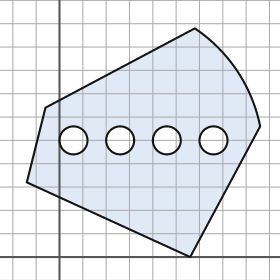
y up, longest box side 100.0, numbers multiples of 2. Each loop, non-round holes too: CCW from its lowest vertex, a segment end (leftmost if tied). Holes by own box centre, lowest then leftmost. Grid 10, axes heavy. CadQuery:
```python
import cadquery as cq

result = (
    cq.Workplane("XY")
    .moveTo(56.0, 0.0)
    .lineTo(86.0, 56.0)
    .threePointArc((76.0, 80.0), (58.0, 98.0))
    .lineTo(-6.0, 64.0)
    .lineTo(-14.0, 32.0)
    .close()
    .moveTo(6.0, 50.0)
    .circle(6.0)
    .moveTo(26.0, 50.0)
    .circle(6.0)
    .moveTo(46.0, 50.0)
    .circle(6.0)
    .moveTo(66.0, 50.0)
    .circle(6.0)
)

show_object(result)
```